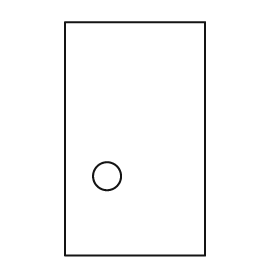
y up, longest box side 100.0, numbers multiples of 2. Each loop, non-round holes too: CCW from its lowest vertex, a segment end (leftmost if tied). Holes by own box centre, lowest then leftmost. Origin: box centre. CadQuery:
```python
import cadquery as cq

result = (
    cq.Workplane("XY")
    .moveTo(-30.0, -50.0)
    .lineTo(30.0, -50.0)
    .lineTo(30.0, 50.0)
    .lineTo(-30.0, 50.0)
    .close()
    .moveTo(-12.0, -16.0)
    .circle(6.0)
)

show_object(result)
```